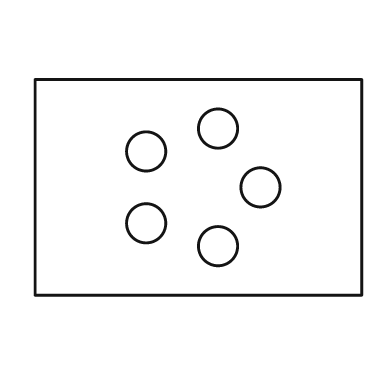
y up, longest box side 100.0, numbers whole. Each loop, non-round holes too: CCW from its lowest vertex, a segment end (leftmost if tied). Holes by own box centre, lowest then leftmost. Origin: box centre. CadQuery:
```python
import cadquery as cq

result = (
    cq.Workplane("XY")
    .moveTo(-50.0, -33.0)
    .lineTo(50.0, -33.0)
    .lineTo(50.0, 33.0)
    .lineTo(-50.0, 33.0)
    .close()
    .moveTo(6.0, -18.0)
    .circle(6.0)
    .moveTo(-16.0, -11.0)
    .circle(6.0)
    .moveTo(19.0, 0.0)
    .circle(6.0)
    .moveTo(-16.0, 11.0)
    .circle(6.0)
    .moveTo(6.0, 18.0)
    .circle(6.0)
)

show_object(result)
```